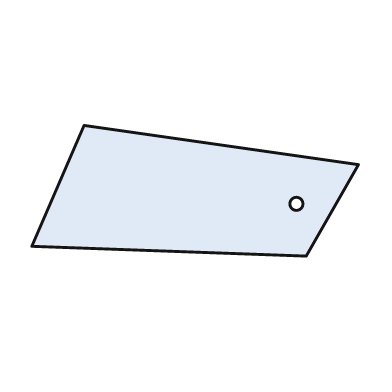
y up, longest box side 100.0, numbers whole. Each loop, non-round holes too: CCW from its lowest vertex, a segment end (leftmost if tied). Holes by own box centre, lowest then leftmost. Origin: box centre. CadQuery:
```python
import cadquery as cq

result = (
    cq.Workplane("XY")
    .moveTo(34.0, -20.0)
    .lineTo(50.0, 8.0)
    .lineTo(-34.0, 20.0)
    .lineTo(-50.0, -17.0)
    .close()
    .moveTo(31.0, -4.0)
    .circle(2.0)
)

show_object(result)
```